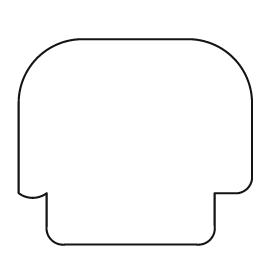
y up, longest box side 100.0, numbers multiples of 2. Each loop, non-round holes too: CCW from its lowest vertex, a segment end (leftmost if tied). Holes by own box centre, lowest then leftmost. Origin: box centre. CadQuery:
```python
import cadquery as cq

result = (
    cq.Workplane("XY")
    .moveTo(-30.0, -44.0)
    .lineTo(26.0, -44.0)
    .threePointArc((32.0, -42.0), (34.0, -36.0))
    .lineTo(34.0, -22.0)
    .lineTo(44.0, -22.0)
    .threePointArc((48.0, -20.0), (50.0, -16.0))
    .lineTo(50.0, 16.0)
    .threePointArc((42.0, 36.0), (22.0, 44.0))
    .lineTo(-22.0, 44.0)
    .threePointArc((-42.0, 36.0), (-50.0, 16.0))
    .lineTo(-50.0, -22.0)
    .threePointArc((-44.0, -24.0), (-38.0, -22.0))
    .lineTo(-38.0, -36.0)
    .threePointArc((-36.0, -42.0), (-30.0, -44.0))
    .close()
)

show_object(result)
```